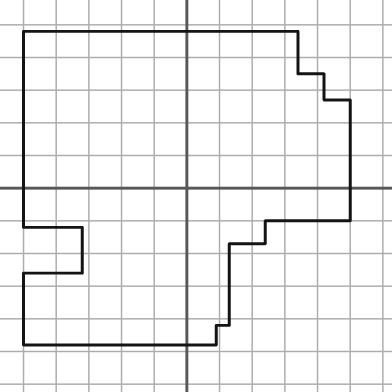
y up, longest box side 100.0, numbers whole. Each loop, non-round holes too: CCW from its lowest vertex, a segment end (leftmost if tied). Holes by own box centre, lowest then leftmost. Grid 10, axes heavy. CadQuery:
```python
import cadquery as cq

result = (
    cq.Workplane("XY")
    .moveTo(-50.0, -48.0)
    .lineTo(9.0, -48.0)
    .lineTo(9.0, -42.0)
    .lineTo(13.0, -42.0)
    .lineTo(13.0, -17.0)
    .lineTo(24.0, -17.0)
    .lineTo(24.0, -10.0)
    .lineTo(50.0, -10.0)
    .lineTo(50.0, 27.0)
    .lineTo(42.0, 27.0)
    .lineTo(42.0, 35.0)
    .lineTo(34.0, 35.0)
    .lineTo(34.0, 48.0)
    .lineTo(-50.0, 48.0)
    .lineTo(-50.0, -12.0)
    .lineTo(-32.0, -12.0)
    .lineTo(-32.0, -26.0)
    .lineTo(-50.0, -26.0)
    .close()
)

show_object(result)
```